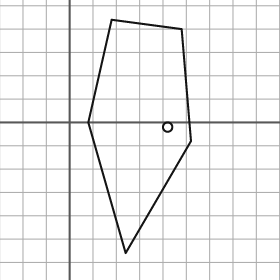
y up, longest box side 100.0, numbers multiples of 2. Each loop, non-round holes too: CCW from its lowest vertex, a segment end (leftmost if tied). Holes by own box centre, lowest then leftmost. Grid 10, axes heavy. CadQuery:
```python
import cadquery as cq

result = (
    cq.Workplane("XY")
    .moveTo(24.0, -56.0)
    .lineTo(52.0, -8.0)
    .lineTo(48.0, 40.0)
    .lineTo(18.0, 44.0)
    .lineTo(8.0, 0.0)
    .close()
    .moveTo(42.0, -2.0)
    .circle(2.0)
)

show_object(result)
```